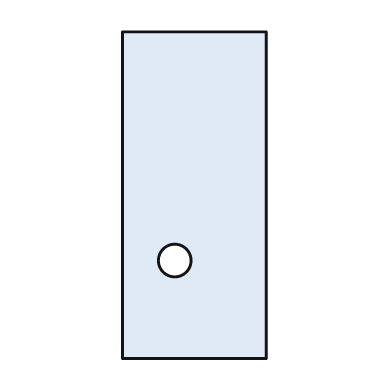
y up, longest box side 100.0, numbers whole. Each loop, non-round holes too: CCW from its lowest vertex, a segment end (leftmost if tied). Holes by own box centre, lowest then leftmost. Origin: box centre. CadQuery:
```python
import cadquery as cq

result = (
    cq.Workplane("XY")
    .moveTo(-22.0, -50.0)
    .lineTo(22.0, -50.0)
    .lineTo(22.0, 50.0)
    .lineTo(-22.0, 50.0)
    .close()
    .moveTo(-6.0, -20.0)
    .circle(5.0)
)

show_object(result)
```